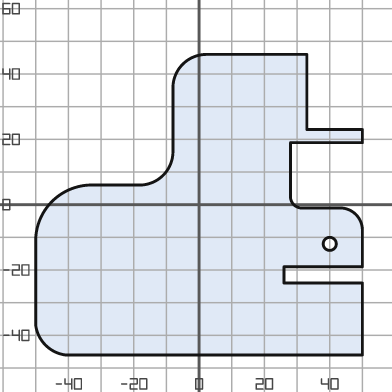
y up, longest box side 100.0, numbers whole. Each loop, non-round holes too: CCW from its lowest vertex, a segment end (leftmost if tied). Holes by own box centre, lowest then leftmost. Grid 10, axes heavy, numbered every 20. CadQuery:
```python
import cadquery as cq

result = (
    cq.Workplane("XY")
    .moveTo(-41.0, -46.0)
    .lineTo(50.0, -46.0)
    .lineTo(50.0, -24.0)
    .lineTo(26.0, -24.0)
    .lineTo(26.0, -19.0)
    .lineTo(50.0, -19.0)
    .lineTo(50.0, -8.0)
    .threePointArc((48.0, -3.0), (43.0, -1.0))
    .lineTo(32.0, -1.0)
    .threePointArc((29.0, 0.0), (28.0, 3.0))
    .lineTo(28.0, 19.0)
    .lineTo(50.0, 19.0)
    .lineTo(50.0, 23.0)
    .lineTo(33.0, 23.0)
    .lineTo(33.0, 46.0)
    .lineTo(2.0, 46.0)
    .threePointArc((-5.0, 43.0), (-8.0, 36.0))
    .lineTo(-8.0, 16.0)
    .threePointArc((-11.0, 9.0), (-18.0, 6.0))
    .lineTo(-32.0, 6.0)
    .threePointArc((-45.0, 1.0), (-50.0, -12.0))
    .lineTo(-50.0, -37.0)
    .threePointArc((-47.0, -43.0), (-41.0, -46.0))
    .close()
    .moveTo(40.0, -12.0)
    .circle(2.0)
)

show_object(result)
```